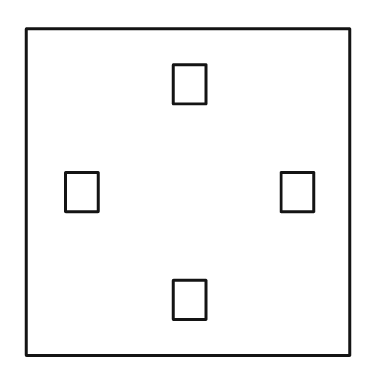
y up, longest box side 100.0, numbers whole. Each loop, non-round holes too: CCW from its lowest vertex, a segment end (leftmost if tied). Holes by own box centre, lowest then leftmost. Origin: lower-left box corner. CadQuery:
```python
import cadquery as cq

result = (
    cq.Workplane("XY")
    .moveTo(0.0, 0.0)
    .lineTo(99.0, 0.0)
    .lineTo(99.0, 100.0)
    .lineTo(0.0, 100.0)
    .close()
    .moveTo(45.0, 11.0)
    .lineTo(55.0, 11.0)
    .lineTo(55.0, 23.0)
    .lineTo(45.0, 23.0)
    .close()
    .moveTo(12.0, 44.0)
    .lineTo(22.0, 44.0)
    .lineTo(22.0, 56.0)
    .lineTo(12.0, 56.0)
    .close()
    .moveTo(78.0, 44.0)
    .lineTo(88.0, 44.0)
    .lineTo(88.0, 56.0)
    .lineTo(78.0, 56.0)
    .close()
    .moveTo(45.0, 77.0)
    .lineTo(55.0, 77.0)
    .lineTo(55.0, 89.0)
    .lineTo(45.0, 89.0)
    .close()
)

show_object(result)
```